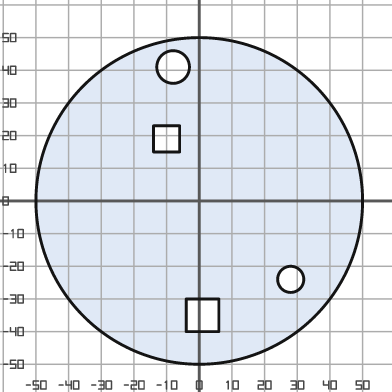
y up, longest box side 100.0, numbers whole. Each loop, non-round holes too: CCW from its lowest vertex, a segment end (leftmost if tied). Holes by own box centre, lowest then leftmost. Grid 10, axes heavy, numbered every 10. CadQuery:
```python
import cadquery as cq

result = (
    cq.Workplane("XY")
    .moveTo(0.0, 0.0)
    .circle(50.0)
    .moveTo(-4.0, -40.0)
    .lineTo(6.0, -40.0)
    .lineTo(6.0, -30.0)
    .lineTo(-4.0, -30.0)
    .close()
    .moveTo(28.0, -24.0)
    .circle(4.0)
    .moveTo(-14.0, 15.0)
    .lineTo(-6.0, 15.0)
    .lineTo(-6.0, 23.0)
    .lineTo(-14.0, 23.0)
    .close()
    .moveTo(-8.0, 41.0)
    .circle(5.0)
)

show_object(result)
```